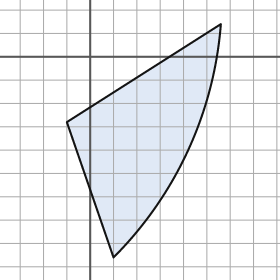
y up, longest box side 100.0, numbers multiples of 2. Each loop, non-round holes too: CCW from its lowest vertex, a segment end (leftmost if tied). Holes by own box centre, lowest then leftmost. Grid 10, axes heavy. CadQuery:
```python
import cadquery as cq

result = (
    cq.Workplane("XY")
    .moveTo(10.0, -86.0)
    .threePointArc((42.0, -40.0), (56.0, 14.0))
    .lineTo(-10.0, -28.0)
    .close()
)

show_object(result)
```